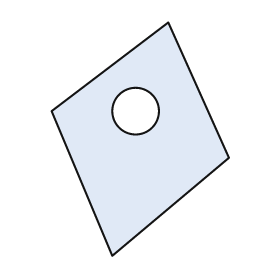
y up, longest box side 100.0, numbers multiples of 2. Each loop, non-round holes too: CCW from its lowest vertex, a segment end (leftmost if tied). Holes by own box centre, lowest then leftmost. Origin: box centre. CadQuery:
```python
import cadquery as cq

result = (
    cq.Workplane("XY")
    .moveTo(-12.0, -50.0)
    .lineTo(38.0, -8.0)
    .lineTo(12.0, 50.0)
    .lineTo(-38.0, 12.0)
    .close()
    .moveTo(-2.0, 12.0)
    .circle(10.0)
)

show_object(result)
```